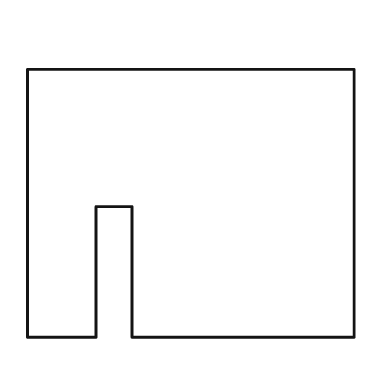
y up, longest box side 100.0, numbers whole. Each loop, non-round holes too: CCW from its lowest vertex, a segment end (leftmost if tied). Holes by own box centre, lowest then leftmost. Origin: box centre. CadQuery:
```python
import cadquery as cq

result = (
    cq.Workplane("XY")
    .moveTo(-50.0, -41.0)
    .lineTo(-29.0, -41.0)
    .lineTo(-29.0, -1.0)
    .lineTo(-18.0, -1.0)
    .lineTo(-18.0, -41.0)
    .lineTo(50.0, -41.0)
    .lineTo(50.0, 41.0)
    .lineTo(-50.0, 41.0)
    .close()
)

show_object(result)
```